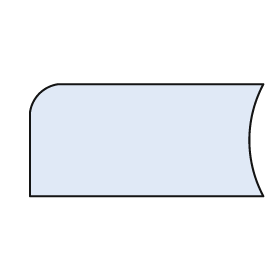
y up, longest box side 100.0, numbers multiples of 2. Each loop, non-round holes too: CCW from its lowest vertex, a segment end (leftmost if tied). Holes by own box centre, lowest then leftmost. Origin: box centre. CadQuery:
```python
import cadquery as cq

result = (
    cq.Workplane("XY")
    .moveTo(-50.0, -24.0)
    .lineTo(50.0, -24.0)
    .threePointArc((44.0, 0.0), (50.0, 24.0))
    .lineTo(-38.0, 24.0)
    .threePointArc((-46.0, 20.0), (-50.0, 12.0))
    .close()
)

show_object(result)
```